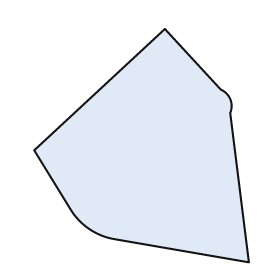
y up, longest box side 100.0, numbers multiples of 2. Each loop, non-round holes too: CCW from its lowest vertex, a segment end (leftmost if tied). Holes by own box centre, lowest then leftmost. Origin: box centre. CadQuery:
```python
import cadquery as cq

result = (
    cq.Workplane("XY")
    .moveTo(46.0, -50.0)
    .lineTo(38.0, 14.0)
    .threePointArc((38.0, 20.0), (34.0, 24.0))
    .lineTo(10.0, 50.0)
    .lineTo(-46.0, -2.0)
    .lineTo(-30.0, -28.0)
    .threePointArc((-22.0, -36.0), (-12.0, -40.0))
    .close()
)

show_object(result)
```